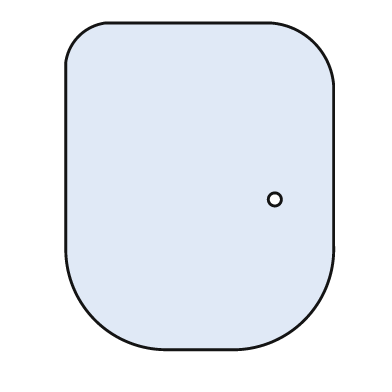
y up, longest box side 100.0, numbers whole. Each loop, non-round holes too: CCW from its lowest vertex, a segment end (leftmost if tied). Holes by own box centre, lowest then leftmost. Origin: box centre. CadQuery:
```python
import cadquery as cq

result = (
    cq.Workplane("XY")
    .moveTo(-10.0, -50.0)
    .lineTo(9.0, -50.0)
    .threePointArc((32.0, -41.0), (41.0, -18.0))
    .lineTo(41.0, 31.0)
    .threePointArc((35.0, 44.0), (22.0, 50.0))
    .lineTo(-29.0, 50.0)
    .threePointArc((-37.0, 46.0), (-41.0, 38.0))
    .lineTo(-41.0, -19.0)
    .threePointArc((-32.0, -41.0), (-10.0, -50.0))
    .close()
    .moveTo(23.0, -4.0)
    .circle(2.0)
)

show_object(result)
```